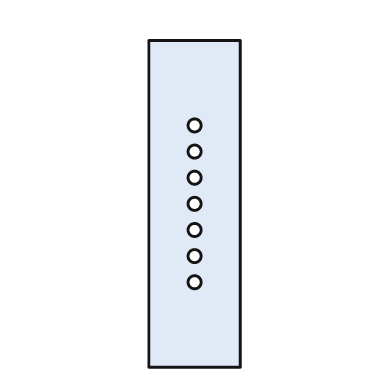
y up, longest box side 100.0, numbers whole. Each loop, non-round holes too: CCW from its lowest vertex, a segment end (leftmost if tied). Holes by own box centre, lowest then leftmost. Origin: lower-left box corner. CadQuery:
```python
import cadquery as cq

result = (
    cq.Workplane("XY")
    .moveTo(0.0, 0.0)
    .lineTo(28.0, 0.0)
    .lineTo(28.0, 100.0)
    .lineTo(0.0, 100.0)
    .close()
    .moveTo(14.0, 26.0)
    .circle(2.0)
    .moveTo(14.0, 34.0)
    .circle(2.0)
    .moveTo(14.0, 42.0)
    .circle(2.0)
    .moveTo(14.0, 50.0)
    .circle(2.0)
    .moveTo(14.0, 58.0)
    .circle(2.0)
    .moveTo(14.0, 66.0)
    .circle(2.0)
    .moveTo(14.0, 74.0)
    .circle(2.0)
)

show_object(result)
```